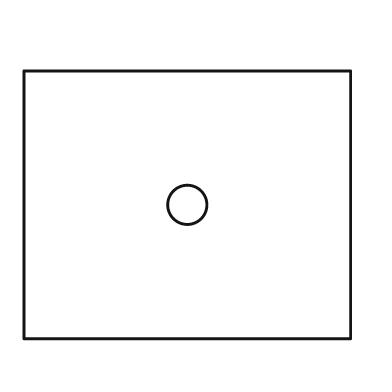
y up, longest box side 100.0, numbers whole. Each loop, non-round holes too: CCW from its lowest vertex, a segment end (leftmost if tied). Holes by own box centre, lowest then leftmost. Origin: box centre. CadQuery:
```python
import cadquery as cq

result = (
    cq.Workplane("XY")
    .moveTo(-50.0, -41.0)
    .lineTo(50.0, -41.0)
    .lineTo(50.0, 41.0)
    .lineTo(-50.0, 41.0)
    .close()
    .moveTo(0.0, 0.0)
    .circle(6.0)
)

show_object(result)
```